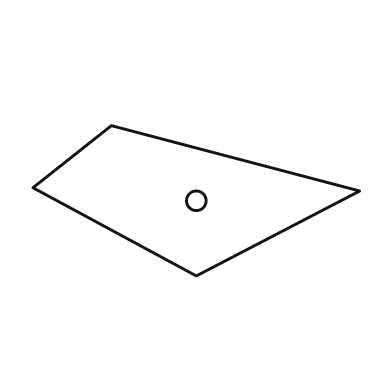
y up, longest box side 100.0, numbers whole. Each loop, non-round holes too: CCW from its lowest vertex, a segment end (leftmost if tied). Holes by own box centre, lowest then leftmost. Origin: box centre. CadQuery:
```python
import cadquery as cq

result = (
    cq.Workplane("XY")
    .moveTo(0.0, -23.0)
    .lineTo(50.0, 3.0)
    .lineTo(-26.0, 23.0)
    .lineTo(-50.0, 4.0)
    .close()
    .moveTo(0.0, 0.0)
    .circle(3.0)
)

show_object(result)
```